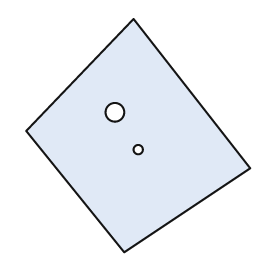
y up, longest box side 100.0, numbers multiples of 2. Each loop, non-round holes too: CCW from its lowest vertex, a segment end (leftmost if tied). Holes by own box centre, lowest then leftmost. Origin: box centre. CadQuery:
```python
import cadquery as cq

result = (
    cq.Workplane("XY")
    .moveTo(-6.0, -50.0)
    .lineTo(48.0, -14.0)
    .lineTo(-2.0, 50.0)
    .lineTo(-48.0, 2.0)
    .close()
    .moveTo(0.0, -6.0)
    .circle(2.0)
    .moveTo(-10.0, 10.0)
    .circle(4.0)
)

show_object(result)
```